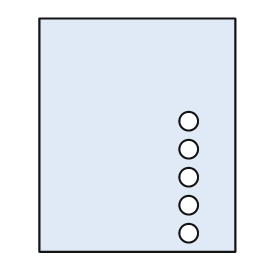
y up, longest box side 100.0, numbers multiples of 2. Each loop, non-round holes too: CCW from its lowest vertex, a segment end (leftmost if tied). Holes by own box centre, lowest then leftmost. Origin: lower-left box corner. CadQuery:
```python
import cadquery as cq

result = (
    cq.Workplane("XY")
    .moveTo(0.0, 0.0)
    .lineTo(84.0, 0.0)
    .lineTo(84.0, 100.0)
    .lineTo(0.0, 100.0)
    .close()
    .moveTo(64.0, 8.0)
    .circle(4.0)
    .moveTo(64.0, 20.0)
    .circle(4.0)
    .moveTo(64.0, 32.0)
    .circle(4.0)
    .moveTo(64.0, 44.0)
    .circle(4.0)
    .moveTo(64.0, 56.0)
    .circle(4.0)
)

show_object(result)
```